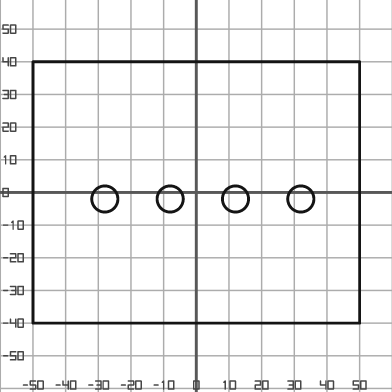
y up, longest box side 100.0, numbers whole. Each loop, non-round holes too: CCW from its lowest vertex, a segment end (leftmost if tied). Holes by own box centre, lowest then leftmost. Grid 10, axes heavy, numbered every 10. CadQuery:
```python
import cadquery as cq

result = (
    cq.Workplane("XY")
    .moveTo(-50.0, -40.0)
    .lineTo(50.0, -40.0)
    .lineTo(50.0, 40.0)
    .lineTo(-50.0, 40.0)
    .close()
    .moveTo(-28.0, -2.0)
    .circle(4.0)
    .moveTo(-8.0, -2.0)
    .circle(4.0)
    .moveTo(12.0, -2.0)
    .circle(4.0)
    .moveTo(32.0, -2.0)
    .circle(4.0)
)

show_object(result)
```